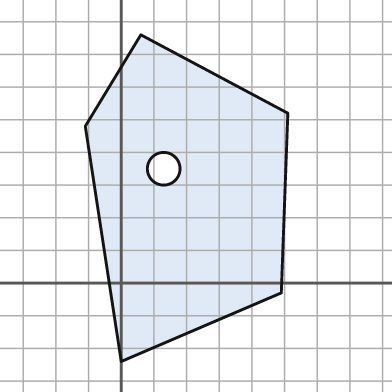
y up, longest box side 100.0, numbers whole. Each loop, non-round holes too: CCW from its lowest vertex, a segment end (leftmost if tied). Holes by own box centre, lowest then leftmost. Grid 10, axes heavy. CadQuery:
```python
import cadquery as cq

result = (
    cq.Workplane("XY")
    .moveTo(0.0, -24.0)
    .lineTo(49.0, -3.0)
    .lineTo(51.0, 52.0)
    .lineTo(6.0, 76.0)
    .lineTo(-11.0, 48.0)
    .close()
    .moveTo(13.0, 35.0)
    .circle(5.0)
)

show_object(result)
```